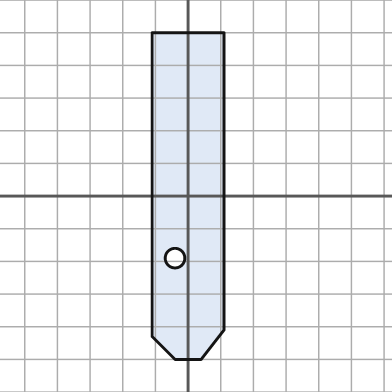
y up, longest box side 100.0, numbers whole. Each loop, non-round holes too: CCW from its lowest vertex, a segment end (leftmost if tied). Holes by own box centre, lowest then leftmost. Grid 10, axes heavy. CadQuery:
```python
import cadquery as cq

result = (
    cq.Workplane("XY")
    .moveTo(-4.0, -50.0)
    .lineTo(4.0, -50.0)
    .lineTo(11.0, -41.0)
    .lineTo(11.0, 50.0)
    .lineTo(-11.0, 50.0)
    .lineTo(-11.0, -43.0)
    .close()
    .moveTo(-4.0, -19.0)
    .circle(3.0)
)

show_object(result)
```